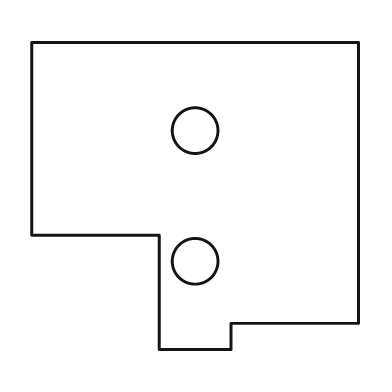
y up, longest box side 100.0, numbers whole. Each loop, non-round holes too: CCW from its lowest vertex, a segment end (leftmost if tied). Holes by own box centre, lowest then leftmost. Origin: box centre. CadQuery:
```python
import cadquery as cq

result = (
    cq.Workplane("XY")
    .moveTo(-11.0, -47.0)
    .lineTo(11.0, -47.0)
    .lineTo(11.0, -39.0)
    .lineTo(50.0, -39.0)
    .lineTo(50.0, 47.0)
    .lineTo(-50.0, 47.0)
    .lineTo(-50.0, -12.0)
    .lineTo(-11.0, -12.0)
    .close()
    .moveTo(0.0, -20.0)
    .circle(7.0)
    .moveTo(0.0, 20.0)
    .circle(7.0)
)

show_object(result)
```